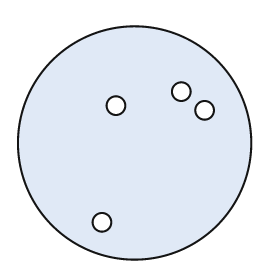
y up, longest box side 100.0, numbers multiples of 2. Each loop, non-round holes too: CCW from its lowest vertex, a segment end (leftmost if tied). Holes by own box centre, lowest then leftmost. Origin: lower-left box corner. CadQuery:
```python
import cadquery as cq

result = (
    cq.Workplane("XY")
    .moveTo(50.0, 50.0)
    .circle(50.0)
    .moveTo(36.0, 16.0)
    .circle(4.0)
    .moveTo(80.0, 64.0)
    .circle(4.0)
    .moveTo(42.0, 66.0)
    .circle(4.0)
    .moveTo(70.0, 72.0)
    .circle(4.0)
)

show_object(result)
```